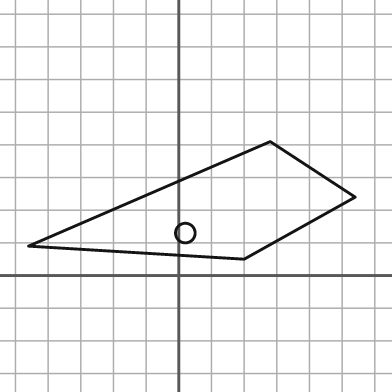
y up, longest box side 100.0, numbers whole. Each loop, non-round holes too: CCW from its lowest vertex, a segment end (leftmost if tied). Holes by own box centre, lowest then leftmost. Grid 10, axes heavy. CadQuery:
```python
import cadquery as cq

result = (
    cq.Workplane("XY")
    .moveTo(20.0, 5.0)
    .lineTo(54.0, 24.0)
    .lineTo(28.0, 41.0)
    .lineTo(-46.0, 9.0)
    .close()
    .moveTo(2.0, 13.0)
    .circle(3.0)
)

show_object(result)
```